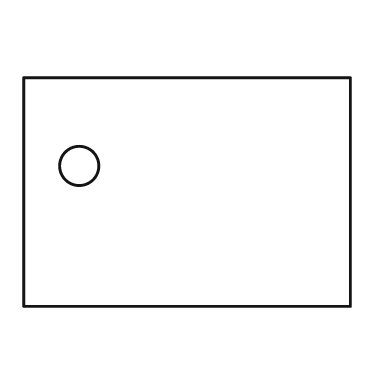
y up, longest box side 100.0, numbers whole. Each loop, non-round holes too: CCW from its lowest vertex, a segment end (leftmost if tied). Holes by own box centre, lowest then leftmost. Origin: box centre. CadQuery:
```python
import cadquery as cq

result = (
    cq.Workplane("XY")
    .moveTo(-50.0, -35.0)
    .lineTo(50.0, -35.0)
    .lineTo(50.0, 35.0)
    .lineTo(-50.0, 35.0)
    .close()
    .moveTo(-33.0, 8.0)
    .circle(6.0)
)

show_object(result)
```